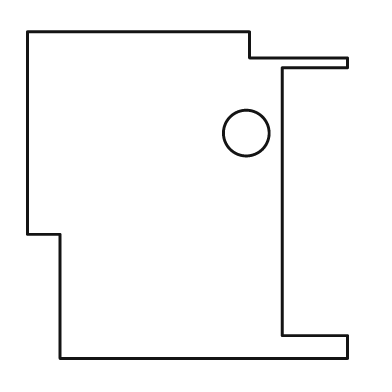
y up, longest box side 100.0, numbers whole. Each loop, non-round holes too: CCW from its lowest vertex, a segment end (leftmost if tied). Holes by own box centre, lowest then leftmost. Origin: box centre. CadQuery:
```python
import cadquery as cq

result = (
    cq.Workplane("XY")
    .moveTo(-39.0, -50.0)
    .lineTo(49.0, -50.0)
    .lineTo(49.0, -43.0)
    .lineTo(29.0, -43.0)
    .lineTo(29.0, 39.0)
    .lineTo(49.0, 39.0)
    .lineTo(49.0, 42.0)
    .lineTo(19.0, 42.0)
    .lineTo(19.0, 50.0)
    .lineTo(-49.0, 50.0)
    .lineTo(-49.0, -12.0)
    .lineTo(-39.0, -12.0)
    .close()
    .moveTo(18.0, 19.0)
    .circle(7.0)
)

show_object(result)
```